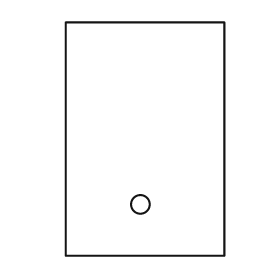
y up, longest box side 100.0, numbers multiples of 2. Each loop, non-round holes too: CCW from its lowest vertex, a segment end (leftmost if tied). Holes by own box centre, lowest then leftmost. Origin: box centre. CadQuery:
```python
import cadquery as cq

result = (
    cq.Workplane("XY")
    .moveTo(-34.0, -50.0)
    .lineTo(34.0, -50.0)
    .lineTo(34.0, 50.0)
    .lineTo(-34.0, 50.0)
    .close()
    .moveTo(-2.0, -28.0)
    .circle(4.0)
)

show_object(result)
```